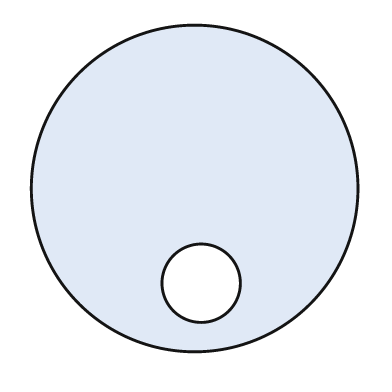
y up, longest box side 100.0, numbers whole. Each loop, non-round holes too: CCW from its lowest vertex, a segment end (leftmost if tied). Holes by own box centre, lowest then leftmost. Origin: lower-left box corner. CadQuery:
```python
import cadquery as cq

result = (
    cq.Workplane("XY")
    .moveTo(50.0, 50.0)
    .circle(50.0)
    .moveTo(52.0, 21.0)
    .circle(12.0)
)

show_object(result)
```